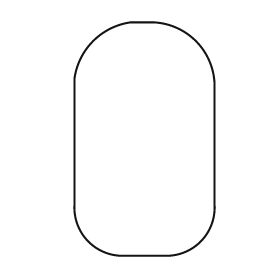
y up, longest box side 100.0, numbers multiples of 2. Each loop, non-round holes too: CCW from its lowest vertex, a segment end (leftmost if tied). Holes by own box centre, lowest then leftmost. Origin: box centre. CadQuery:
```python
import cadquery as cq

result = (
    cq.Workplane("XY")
    .moveTo(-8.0, -50.0)
    .lineTo(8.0, -50.0)
    .threePointArc((24.0, -44.0), (30.0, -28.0))
    .lineTo(30.0, 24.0)
    .threePointArc((22.0, 42.0), (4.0, 50.0))
    .lineTo(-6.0, 50.0)
    .threePointArc((-22.0, 42.0), (-30.0, 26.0))
    .lineTo(-30.0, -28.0)
    .threePointArc((-24.0, -44.0), (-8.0, -50.0))
    .close()
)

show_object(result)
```